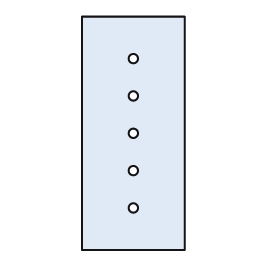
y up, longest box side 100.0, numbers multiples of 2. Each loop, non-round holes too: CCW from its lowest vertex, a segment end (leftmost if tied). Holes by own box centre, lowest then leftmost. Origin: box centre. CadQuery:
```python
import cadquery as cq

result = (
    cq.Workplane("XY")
    .moveTo(-22.0, -50.0)
    .lineTo(22.0, -50.0)
    .lineTo(22.0, 50.0)
    .lineTo(-22.0, 50.0)
    .close()
    .moveTo(0.0, -32.0)
    .circle(2.0)
    .moveTo(0.0, -16.0)
    .circle(2.0)
    .moveTo(0.0, 0.0)
    .circle(2.0)
    .moveTo(0.0, 16.0)
    .circle(2.0)
    .moveTo(0.0, 32.0)
    .circle(2.0)
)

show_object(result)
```